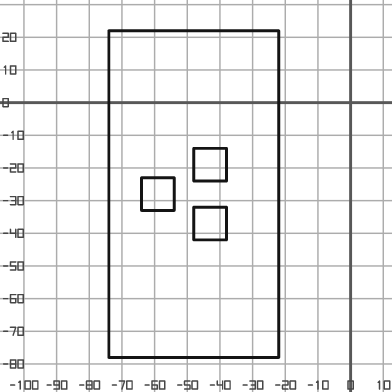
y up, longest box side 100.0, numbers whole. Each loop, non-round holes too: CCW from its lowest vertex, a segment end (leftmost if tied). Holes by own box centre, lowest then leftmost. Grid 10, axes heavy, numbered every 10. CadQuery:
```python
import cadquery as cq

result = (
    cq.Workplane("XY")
    .moveTo(-74.0, -78.0)
    .lineTo(-22.0, -78.0)
    .lineTo(-22.0, 22.0)
    .lineTo(-74.0, 22.0)
    .close()
    .moveTo(-48.0, -42.0)
    .lineTo(-38.0, -42.0)
    .lineTo(-38.0, -32.0)
    .lineTo(-48.0, -32.0)
    .close()
    .moveTo(-64.0, -33.0)
    .lineTo(-54.0, -33.0)
    .lineTo(-54.0, -23.0)
    .lineTo(-64.0, -23.0)
    .close()
    .moveTo(-48.0, -24.0)
    .lineTo(-38.0, -24.0)
    .lineTo(-38.0, -14.0)
    .lineTo(-48.0, -14.0)
    .close()
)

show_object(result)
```